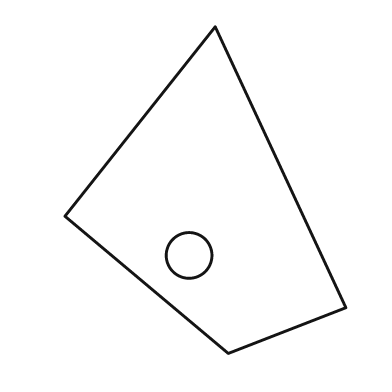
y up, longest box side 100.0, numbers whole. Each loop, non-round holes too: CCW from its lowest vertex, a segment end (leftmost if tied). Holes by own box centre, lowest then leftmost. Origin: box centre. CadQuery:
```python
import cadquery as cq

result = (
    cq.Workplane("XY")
    .moveTo(7.0, -50.0)
    .lineTo(43.0, -36.0)
    .lineTo(3.0, 50.0)
    .lineTo(-43.0, -8.0)
    .close()
    .moveTo(-5.0, -20.0)
    .circle(7.0)
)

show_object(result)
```